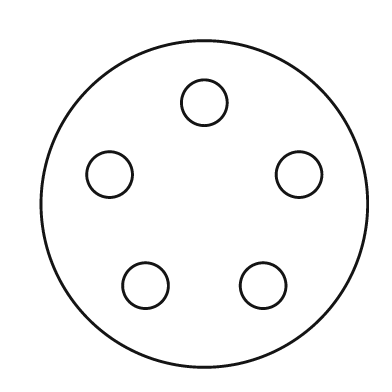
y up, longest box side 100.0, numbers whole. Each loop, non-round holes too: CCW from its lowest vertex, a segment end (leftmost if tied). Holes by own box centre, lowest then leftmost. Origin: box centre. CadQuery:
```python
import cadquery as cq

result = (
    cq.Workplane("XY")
    .moveTo(0.0, 0.0)
    .circle(50.0)
    .moveTo(-18.0, -25.0)
    .circle(7.0)
    .moveTo(18.0, -25.0)
    .circle(7.0)
    .moveTo(-29.0, 9.0)
    .circle(7.0)
    .moveTo(29.0, 9.0)
    .circle(7.0)
    .moveTo(0.0, 31.0)
    .circle(7.0)
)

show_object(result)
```